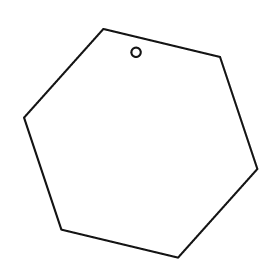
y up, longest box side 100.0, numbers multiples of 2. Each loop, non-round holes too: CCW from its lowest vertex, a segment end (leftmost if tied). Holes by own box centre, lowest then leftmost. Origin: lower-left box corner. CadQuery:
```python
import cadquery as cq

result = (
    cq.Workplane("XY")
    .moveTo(66.0, 0.0)
    .lineTo(100.0, 38.0)
    .lineTo(84.0, 86.0)
    .lineTo(34.0, 98.0)
    .lineTo(0.0, 60.0)
    .lineTo(16.0, 12.0)
    .close()
    .moveTo(48.0, 88.0)
    .circle(2.0)
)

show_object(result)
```